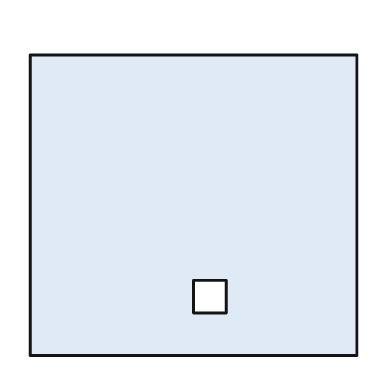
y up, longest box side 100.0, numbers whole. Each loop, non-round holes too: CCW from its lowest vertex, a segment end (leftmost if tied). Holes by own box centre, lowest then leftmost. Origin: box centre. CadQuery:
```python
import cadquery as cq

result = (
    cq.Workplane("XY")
    .moveTo(-50.0, -46.0)
    .lineTo(50.0, -46.0)
    .lineTo(50.0, 46.0)
    .lineTo(-50.0, 46.0)
    .close()
    .moveTo(0.0, -33.0)
    .lineTo(10.0, -33.0)
    .lineTo(10.0, -23.0)
    .lineTo(0.0, -23.0)
    .close()
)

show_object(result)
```